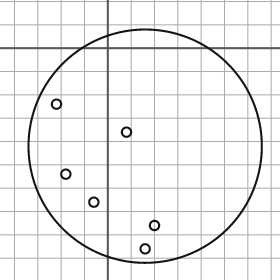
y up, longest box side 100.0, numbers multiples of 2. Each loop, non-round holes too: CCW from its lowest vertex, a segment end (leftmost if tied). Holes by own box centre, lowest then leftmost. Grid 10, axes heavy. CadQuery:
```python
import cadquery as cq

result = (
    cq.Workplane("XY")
    .moveTo(16.0, -42.0)
    .circle(50.0)
    .moveTo(16.0, -86.0)
    .circle(2.0)
    .moveTo(20.0, -76.0)
    .circle(2.0)
    .moveTo(-6.0, -66.0)
    .circle(2.0)
    .moveTo(-18.0, -54.0)
    .circle(2.0)
    .moveTo(8.0, -36.0)
    .circle(2.0)
    .moveTo(-22.0, -24.0)
    .circle(2.0)
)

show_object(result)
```